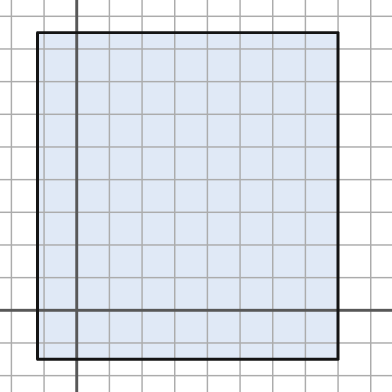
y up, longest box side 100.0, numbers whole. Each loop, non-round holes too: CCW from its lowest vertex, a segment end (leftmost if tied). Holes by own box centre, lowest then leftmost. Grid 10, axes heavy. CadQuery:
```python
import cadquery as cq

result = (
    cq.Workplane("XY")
    .moveTo(-12.0, -15.0)
    .lineTo(80.0, -15.0)
    .lineTo(80.0, 85.0)
    .lineTo(-12.0, 85.0)
    .close()
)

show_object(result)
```